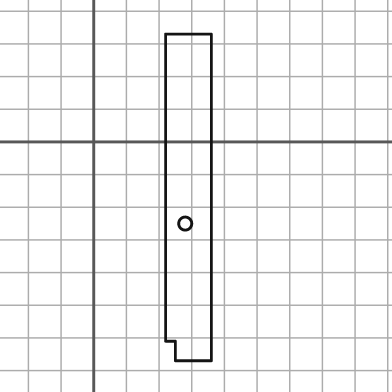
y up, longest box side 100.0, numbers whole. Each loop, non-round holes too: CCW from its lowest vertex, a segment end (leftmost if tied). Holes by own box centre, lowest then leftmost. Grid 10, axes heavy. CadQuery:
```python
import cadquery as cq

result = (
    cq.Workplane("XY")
    .moveTo(25.0, -67.0)
    .lineTo(36.0, -67.0)
    .lineTo(36.0, 33.0)
    .lineTo(22.0, 33.0)
    .lineTo(22.0, -61.0)
    .lineTo(25.0, -61.0)
    .close()
    .moveTo(28.0, -25.0)
    .circle(2.0)
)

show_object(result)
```